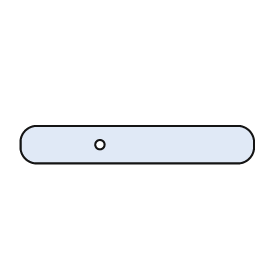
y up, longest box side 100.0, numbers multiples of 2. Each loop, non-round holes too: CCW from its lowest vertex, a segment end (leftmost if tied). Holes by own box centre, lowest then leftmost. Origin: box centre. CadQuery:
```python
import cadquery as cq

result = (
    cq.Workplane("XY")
    .moveTo(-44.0, -8.0)
    .lineTo(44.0, -8.0)
    .threePointArc((48.0, -6.0), (50.0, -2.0))
    .lineTo(50.0, 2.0)
    .threePointArc((48.0, 6.0), (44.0, 8.0))
    .lineTo(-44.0, 8.0)
    .threePointArc((-48.0, 6.0), (-50.0, 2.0))
    .lineTo(-50.0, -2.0)
    .threePointArc((-48.0, -6.0), (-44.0, -8.0))
    .close()
    .moveTo(-16.0, 0.0)
    .circle(2.0)
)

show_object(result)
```